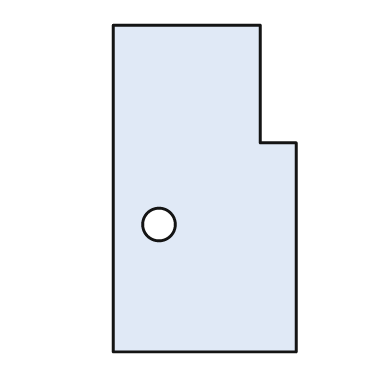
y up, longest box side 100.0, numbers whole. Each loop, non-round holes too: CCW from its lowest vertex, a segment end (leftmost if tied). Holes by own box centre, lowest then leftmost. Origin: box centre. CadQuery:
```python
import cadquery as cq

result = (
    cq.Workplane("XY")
    .moveTo(-28.0, -50.0)
    .lineTo(28.0, -50.0)
    .lineTo(28.0, 14.0)
    .lineTo(17.0, 14.0)
    .lineTo(17.0, 50.0)
    .lineTo(-28.0, 50.0)
    .close()
    .moveTo(-14.0, -11.0)
    .circle(5.0)
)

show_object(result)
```